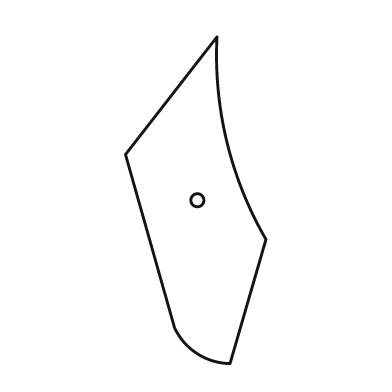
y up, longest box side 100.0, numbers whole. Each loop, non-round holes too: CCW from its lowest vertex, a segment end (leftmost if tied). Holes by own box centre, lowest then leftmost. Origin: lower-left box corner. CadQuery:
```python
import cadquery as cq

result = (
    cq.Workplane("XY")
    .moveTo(32.0, 0.0)
    .lineTo(43.0, 38.0)
    .threePointArc((31.0, 68.0), (28.0, 100.0))
    .lineTo(0.0, 64.0)
    .lineTo(15.0, 11.0)
    .threePointArc((22.0, 3.0), (32.0, 0.0))
    .close()
    .moveTo(22.0, 50.0)
    .circle(2.0)
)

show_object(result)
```